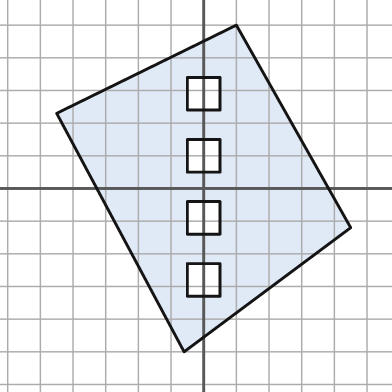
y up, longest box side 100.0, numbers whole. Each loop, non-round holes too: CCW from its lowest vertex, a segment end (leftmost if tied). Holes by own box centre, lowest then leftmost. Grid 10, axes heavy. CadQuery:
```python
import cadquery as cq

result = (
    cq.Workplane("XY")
    .moveTo(-6.0, -50.0)
    .lineTo(45.0, -12.0)
    .lineTo(10.0, 50.0)
    .lineTo(-45.0, 23.0)
    .close()
    .moveTo(-5.0, -33.0)
    .lineTo(5.0, -33.0)
    .lineTo(5.0, -23.0)
    .lineTo(-5.0, -23.0)
    .close()
    .moveTo(-5.0, -14.0)
    .lineTo(5.0, -14.0)
    .lineTo(5.0, -4.0)
    .lineTo(-5.0, -4.0)
    .close()
    .moveTo(-5.0, 5.0)
    .lineTo(5.0, 5.0)
    .lineTo(5.0, 15.0)
    .lineTo(-5.0, 15.0)
    .close()
    .moveTo(-5.0, 24.0)
    .lineTo(5.0, 24.0)
    .lineTo(5.0, 34.0)
    .lineTo(-5.0, 34.0)
    .close()
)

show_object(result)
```